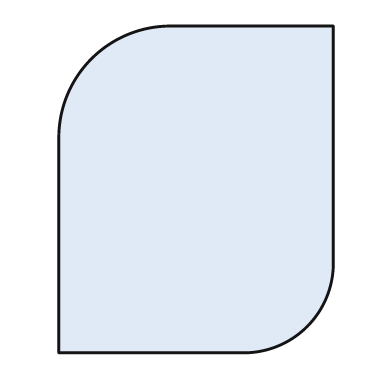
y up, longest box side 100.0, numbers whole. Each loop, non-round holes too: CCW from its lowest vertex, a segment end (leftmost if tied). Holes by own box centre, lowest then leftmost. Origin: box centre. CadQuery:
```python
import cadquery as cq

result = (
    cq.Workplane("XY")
    .moveTo(-42.0, -50.0)
    .lineTo(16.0, -50.0)
    .threePointArc((34.0, -42.0), (42.0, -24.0))
    .lineTo(42.0, 50.0)
    .lineTo(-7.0, 50.0)
    .threePointArc((-32.0, 40.0), (-42.0, 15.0))
    .close()
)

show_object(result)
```